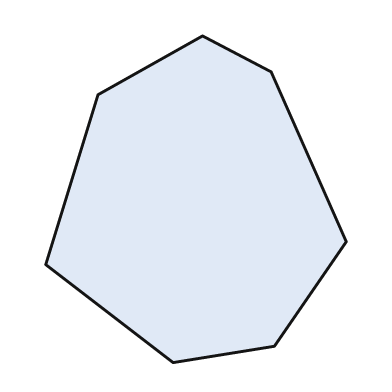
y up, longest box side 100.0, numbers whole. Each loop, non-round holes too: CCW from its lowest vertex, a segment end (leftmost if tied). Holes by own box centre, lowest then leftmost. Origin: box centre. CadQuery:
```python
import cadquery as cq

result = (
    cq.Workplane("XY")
    .moveTo(-7.0, -50.0)
    .lineTo(24.0, -45.0)
    .lineTo(46.0, -13.0)
    .lineTo(23.0, 39.0)
    .lineTo(2.0, 50.0)
    .lineTo(-30.0, 32.0)
    .lineTo(-46.0, -20.0)
    .close()
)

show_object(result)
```